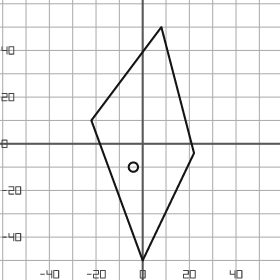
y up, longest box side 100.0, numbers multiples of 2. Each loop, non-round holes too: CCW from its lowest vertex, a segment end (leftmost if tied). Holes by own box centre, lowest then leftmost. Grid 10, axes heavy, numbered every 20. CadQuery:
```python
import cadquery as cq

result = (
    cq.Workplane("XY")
    .moveTo(0.0, -50.0)
    .lineTo(22.0, -4.0)
    .lineTo(8.0, 50.0)
    .lineTo(-22.0, 10.0)
    .close()
    .moveTo(-4.0, -10.0)
    .circle(2.0)
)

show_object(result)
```